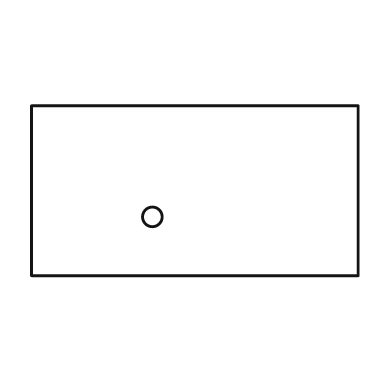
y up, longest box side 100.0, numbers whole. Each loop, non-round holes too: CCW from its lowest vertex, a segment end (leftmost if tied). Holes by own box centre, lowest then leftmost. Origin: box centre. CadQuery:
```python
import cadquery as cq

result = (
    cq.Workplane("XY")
    .moveTo(-50.0, -26.0)
    .lineTo(50.0, -26.0)
    .lineTo(50.0, 26.0)
    .lineTo(-50.0, 26.0)
    .close()
    .moveTo(-13.0, -8.0)
    .circle(3.0)
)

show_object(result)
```